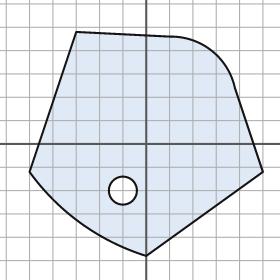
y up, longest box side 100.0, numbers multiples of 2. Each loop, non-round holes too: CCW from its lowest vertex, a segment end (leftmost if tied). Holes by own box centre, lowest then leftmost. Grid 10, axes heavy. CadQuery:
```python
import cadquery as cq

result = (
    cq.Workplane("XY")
    .moveTo(0.0, -48.0)
    .lineTo(50.0, -12.0)
    .lineTo(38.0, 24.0)
    .threePointArc((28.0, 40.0), (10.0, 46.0))
    .lineTo(-30.0, 48.0)
    .lineTo(-50.0, -12.0)
    .threePointArc((-28.0, -34.0), (0.0, -48.0))
    .close()
    .moveTo(-10.0, -20.0)
    .circle(6.0)
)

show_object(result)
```